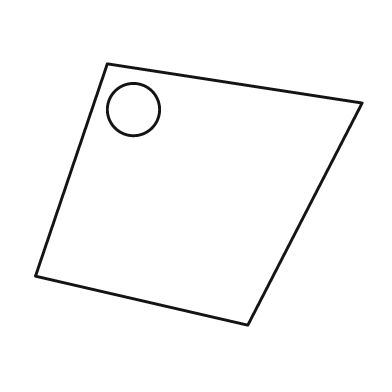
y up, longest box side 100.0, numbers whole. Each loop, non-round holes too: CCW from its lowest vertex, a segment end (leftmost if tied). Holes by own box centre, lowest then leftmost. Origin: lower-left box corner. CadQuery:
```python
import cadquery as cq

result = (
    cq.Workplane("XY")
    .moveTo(65.0, 0.0)
    .lineTo(100.0, 68.0)
    .lineTo(22.0, 80.0)
    .lineTo(0.0, 15.0)
    .close()
    .moveTo(30.0, 66.0)
    .circle(8.0)
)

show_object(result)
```